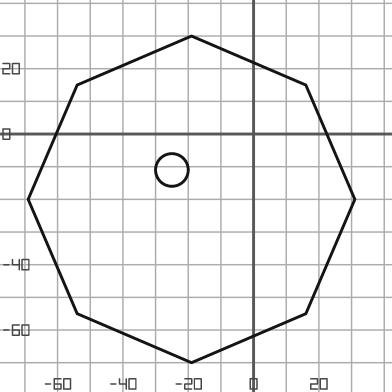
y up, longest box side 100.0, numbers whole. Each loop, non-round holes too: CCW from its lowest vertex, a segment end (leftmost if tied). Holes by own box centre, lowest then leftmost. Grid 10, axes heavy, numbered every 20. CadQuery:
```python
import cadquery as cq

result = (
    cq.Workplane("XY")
    .moveTo(-19.0, -70.0)
    .lineTo(16.0, -55.0)
    .lineTo(31.0, -20.0)
    .lineTo(16.0, 15.0)
    .lineTo(-19.0, 30.0)
    .lineTo(-54.0, 15.0)
    .lineTo(-69.0, -20.0)
    .lineTo(-54.0, -55.0)
    .close()
    .moveTo(-25.0, -11.0)
    .circle(5.0)
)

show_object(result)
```